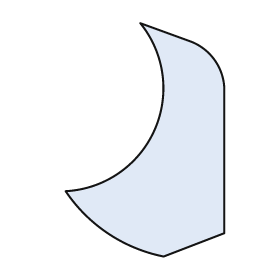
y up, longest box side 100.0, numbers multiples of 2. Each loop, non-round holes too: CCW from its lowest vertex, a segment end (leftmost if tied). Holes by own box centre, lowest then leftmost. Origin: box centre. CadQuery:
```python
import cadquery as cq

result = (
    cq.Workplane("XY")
    .moveTo(8.0, -50.0)
    .lineTo(34.0, -40.0)
    .lineTo(34.0, 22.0)
    .threePointArc((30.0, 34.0), (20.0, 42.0))
    .lineTo(-2.0, 50.0)
    .threePointArc((4.0, 4.0), (-34.0, -22.0))
    .threePointArc((-16.0, -40.0), (8.0, -50.0))
    .close()
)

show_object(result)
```